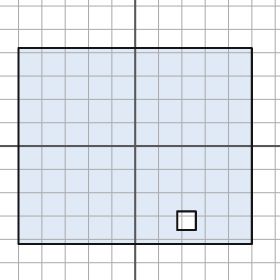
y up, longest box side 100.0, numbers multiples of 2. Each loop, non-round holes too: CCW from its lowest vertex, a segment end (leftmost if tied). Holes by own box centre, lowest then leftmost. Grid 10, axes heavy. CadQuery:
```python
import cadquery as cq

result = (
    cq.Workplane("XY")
    .moveTo(-50.0, -42.0)
    .lineTo(50.0, -42.0)
    .lineTo(50.0, 42.0)
    .lineTo(-50.0, 42.0)
    .close()
    .moveTo(18.0, -36.0)
    .lineTo(26.0, -36.0)
    .lineTo(26.0, -28.0)
    .lineTo(18.0, -28.0)
    .close()
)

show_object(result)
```